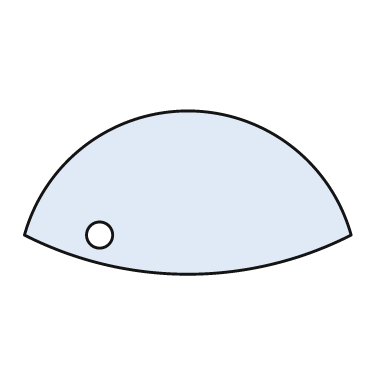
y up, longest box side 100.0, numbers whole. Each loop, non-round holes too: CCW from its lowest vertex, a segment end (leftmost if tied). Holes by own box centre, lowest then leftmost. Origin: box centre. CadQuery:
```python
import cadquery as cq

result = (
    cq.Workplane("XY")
    .moveTo(-50.0, -13.0)
    .threePointArc((0.0, -25.0), (50.0, -13.0))
    .threePointArc((0.0, 25.0), (-50.0, -13.0))
    .close()
    .moveTo(-27.0, -13.0)
    .circle(4.0)
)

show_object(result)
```